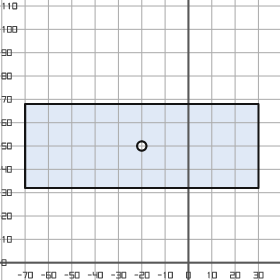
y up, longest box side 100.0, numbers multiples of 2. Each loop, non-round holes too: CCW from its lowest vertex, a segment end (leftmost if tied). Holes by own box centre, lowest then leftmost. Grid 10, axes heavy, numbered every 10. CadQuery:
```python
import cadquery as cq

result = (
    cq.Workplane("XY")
    .moveTo(-70.0, 32.0)
    .lineTo(30.0, 32.0)
    .lineTo(30.0, 68.0)
    .lineTo(-70.0, 68.0)
    .close()
    .moveTo(-20.0, 50.0)
    .circle(2.0)
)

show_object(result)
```